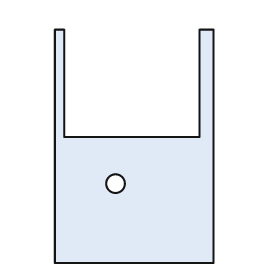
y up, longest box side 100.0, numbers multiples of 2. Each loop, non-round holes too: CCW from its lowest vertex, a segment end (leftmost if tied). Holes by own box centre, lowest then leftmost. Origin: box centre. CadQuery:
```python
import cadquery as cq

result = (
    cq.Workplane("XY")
    .moveTo(-34.0, -50.0)
    .lineTo(34.0, -50.0)
    .lineTo(34.0, 50.0)
    .lineTo(28.0, 50.0)
    .lineTo(28.0, 4.0)
    .lineTo(-30.0, 4.0)
    .lineTo(-30.0, 50.0)
    .lineTo(-34.0, 50.0)
    .close()
    .moveTo(-8.0, -16.0)
    .circle(4.0)
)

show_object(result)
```